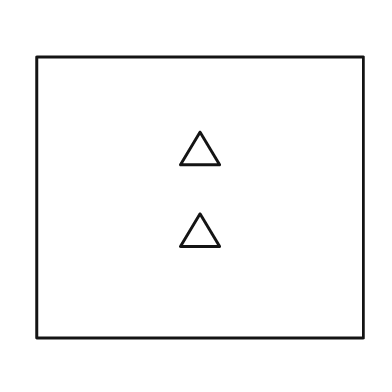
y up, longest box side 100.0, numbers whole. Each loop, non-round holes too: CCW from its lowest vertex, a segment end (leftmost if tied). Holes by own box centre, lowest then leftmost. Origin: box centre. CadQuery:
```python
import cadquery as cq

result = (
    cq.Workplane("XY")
    .moveTo(-50.0, -43.0)
    .lineTo(50.0, -43.0)
    .lineTo(50.0, 43.0)
    .lineTo(-50.0, 43.0)
    .close()
    .moveTo(-6.0, -15.0)
    .lineTo(6.0, -15.0)
    .lineTo(0.0, -5.0)
    .close()
    .moveTo(-6.0, 10.0)
    .lineTo(6.0, 10.0)
    .lineTo(0.0, 20.0)
    .close()
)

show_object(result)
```